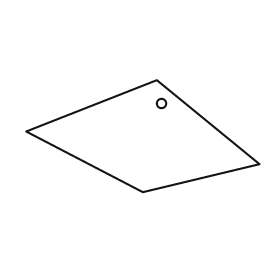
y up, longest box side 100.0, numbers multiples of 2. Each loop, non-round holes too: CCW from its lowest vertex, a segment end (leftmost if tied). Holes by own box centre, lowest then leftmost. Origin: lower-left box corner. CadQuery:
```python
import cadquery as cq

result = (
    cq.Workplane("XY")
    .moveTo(50.0, 0.0)
    .lineTo(100.0, 12.0)
    .lineTo(56.0, 48.0)
    .lineTo(0.0, 26.0)
    .close()
    .moveTo(58.0, 38.0)
    .circle(2.0)
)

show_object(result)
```